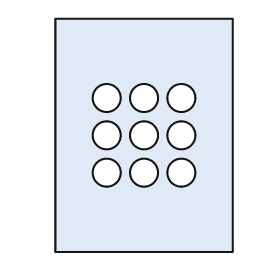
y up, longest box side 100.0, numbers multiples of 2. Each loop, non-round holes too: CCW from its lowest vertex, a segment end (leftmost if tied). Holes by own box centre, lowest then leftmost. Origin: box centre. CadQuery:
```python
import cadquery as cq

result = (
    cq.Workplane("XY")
    .moveTo(-38.0, -50.0)
    .lineTo(38.0, -50.0)
    .lineTo(38.0, 50.0)
    .lineTo(-38.0, 50.0)
    .close()
    .moveTo(-16.0, -16.0)
    .circle(6.0)
    .moveTo(0.0, -16.0)
    .circle(6.0)
    .moveTo(16.0, -16.0)
    .circle(6.0)
    .moveTo(-16.0, 0.0)
    .circle(6.0)
    .moveTo(0.0, 0.0)
    .circle(6.0)
    .moveTo(16.0, 0.0)
    .circle(6.0)
    .moveTo(-16.0, 16.0)
    .circle(6.0)
    .moveTo(0.0, 16.0)
    .circle(6.0)
    .moveTo(16.0, 16.0)
    .circle(6.0)
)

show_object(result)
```